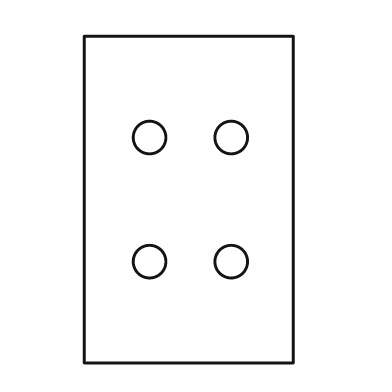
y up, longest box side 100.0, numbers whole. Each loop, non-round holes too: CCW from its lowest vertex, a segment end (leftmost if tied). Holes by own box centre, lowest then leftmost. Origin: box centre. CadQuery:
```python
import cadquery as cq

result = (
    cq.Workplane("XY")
    .moveTo(-32.0, -50.0)
    .lineTo(32.0, -50.0)
    .lineTo(32.0, 50.0)
    .lineTo(-32.0, 50.0)
    .close()
    .moveTo(-12.0, -19.0)
    .circle(5.0)
    .moveTo(13.0, -19.0)
    .circle(5.0)
    .moveTo(-12.0, 19.0)
    .circle(5.0)
    .moveTo(13.0, 19.0)
    .circle(5.0)
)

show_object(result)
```